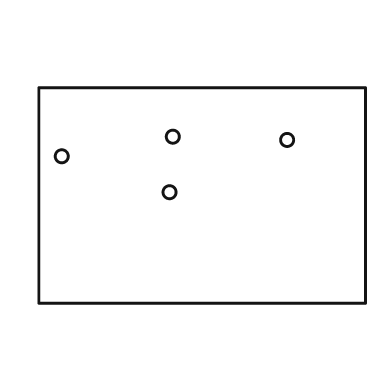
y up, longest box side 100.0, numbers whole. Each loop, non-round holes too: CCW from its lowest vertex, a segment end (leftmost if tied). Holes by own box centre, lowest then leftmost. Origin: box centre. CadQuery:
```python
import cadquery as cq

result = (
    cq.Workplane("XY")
    .moveTo(-50.0, -33.0)
    .lineTo(50.0, -33.0)
    .lineTo(50.0, 33.0)
    .lineTo(-50.0, 33.0)
    .close()
    .moveTo(-10.0, 1.0)
    .circle(2.0)
    .moveTo(-43.0, 12.0)
    .circle(2.0)
    .moveTo(26.0, 17.0)
    .circle(2.0)
    .moveTo(-9.0, 18.0)
    .circle(2.0)
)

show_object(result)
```